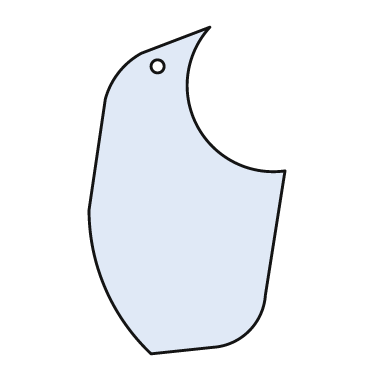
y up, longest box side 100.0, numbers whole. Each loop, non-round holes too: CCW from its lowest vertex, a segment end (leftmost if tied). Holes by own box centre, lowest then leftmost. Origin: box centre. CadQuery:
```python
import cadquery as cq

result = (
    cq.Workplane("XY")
    .moveTo(-11.0, -50.0)
    .lineTo(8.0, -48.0)
    .threePointArc((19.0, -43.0), (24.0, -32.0))
    .lineTo(30.0, 6.0)
    .threePointArc((3.0, 20.0), (7.0, 50.0))
    .lineTo(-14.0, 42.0)
    .threePointArc((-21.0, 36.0), (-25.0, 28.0))
    .lineTo(-30.0, -6.0)
    .threePointArc((-25.0, -30.0), (-11.0, -50.0))
    .close()
    .moveTo(-9.0, 38.0)
    .circle(2.0)
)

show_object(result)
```